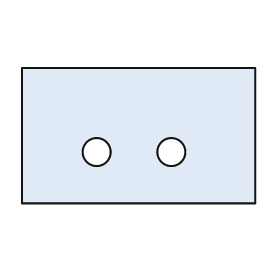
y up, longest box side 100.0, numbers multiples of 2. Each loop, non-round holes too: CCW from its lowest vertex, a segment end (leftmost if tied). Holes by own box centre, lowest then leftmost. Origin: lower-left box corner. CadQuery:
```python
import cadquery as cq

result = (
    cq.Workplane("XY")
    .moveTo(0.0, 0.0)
    .lineTo(100.0, 0.0)
    .lineTo(100.0, 58.0)
    .lineTo(0.0, 58.0)
    .close()
    .moveTo(32.0, 22.0)
    .circle(6.0)
    .moveTo(64.0, 22.0)
    .circle(6.0)
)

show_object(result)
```